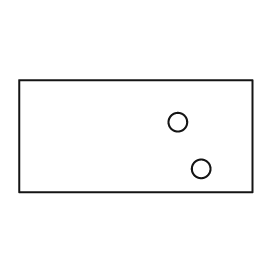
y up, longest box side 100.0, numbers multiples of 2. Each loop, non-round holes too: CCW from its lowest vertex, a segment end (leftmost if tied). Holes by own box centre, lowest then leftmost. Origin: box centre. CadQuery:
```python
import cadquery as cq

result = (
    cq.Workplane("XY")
    .moveTo(-50.0, -24.0)
    .lineTo(50.0, -24.0)
    .lineTo(50.0, 24.0)
    .lineTo(-50.0, 24.0)
    .close()
    .moveTo(28.0, -14.0)
    .circle(4.0)
    .moveTo(18.0, 6.0)
    .circle(4.0)
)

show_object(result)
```